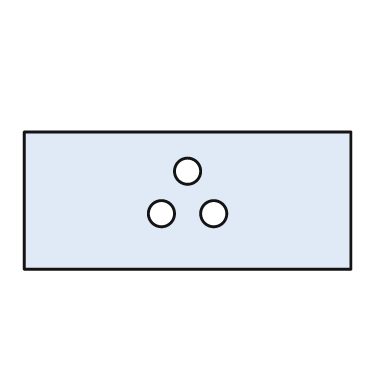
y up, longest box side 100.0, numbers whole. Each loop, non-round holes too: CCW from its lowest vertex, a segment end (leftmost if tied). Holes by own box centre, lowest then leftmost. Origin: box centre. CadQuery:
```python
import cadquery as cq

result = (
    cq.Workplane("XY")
    .moveTo(-50.0, -21.0)
    .lineTo(50.0, -21.0)
    .lineTo(50.0, 21.0)
    .lineTo(-50.0, 21.0)
    .close()
    .moveTo(-8.0, -4.0)
    .circle(4.0)
    .moveTo(8.0, -4.0)
    .circle(4.0)
    .moveTo(0.0, 9.0)
    .circle(4.0)
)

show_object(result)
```